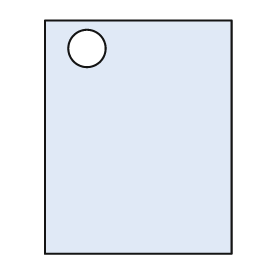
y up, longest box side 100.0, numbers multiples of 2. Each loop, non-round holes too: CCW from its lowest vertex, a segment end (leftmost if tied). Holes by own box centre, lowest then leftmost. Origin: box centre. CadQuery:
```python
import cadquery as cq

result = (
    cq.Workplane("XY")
    .moveTo(-40.0, -50.0)
    .lineTo(40.0, -50.0)
    .lineTo(40.0, 50.0)
    .lineTo(-40.0, 50.0)
    .close()
    .moveTo(-22.0, 38.0)
    .circle(8.0)
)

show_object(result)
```